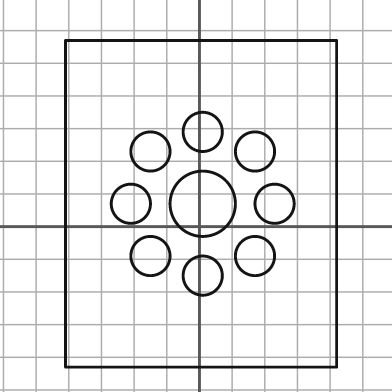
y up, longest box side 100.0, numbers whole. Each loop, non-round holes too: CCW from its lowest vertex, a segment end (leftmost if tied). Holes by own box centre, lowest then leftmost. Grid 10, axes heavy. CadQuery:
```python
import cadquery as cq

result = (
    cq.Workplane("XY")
    .moveTo(-41.0, -43.0)
    .lineTo(42.0, -43.0)
    .lineTo(42.0, 57.0)
    .lineTo(-41.0, 57.0)
    .close()
    .moveTo(1.0, -15.0)
    .circle(6.0)
    .moveTo(-15.0, -9.0)
    .circle(6.0)
    .moveTo(17.0, -9.0)
    .circle(6.0)
    .moveTo(-21.0, 7.0)
    .circle(6.0)
    .moveTo(1.0, 7.0)
    .circle(10.0)
    .moveTo(23.0, 7.0)
    .circle(6.0)
    .moveTo(-15.0, 23.0)
    .circle(6.0)
    .moveTo(17.0, 23.0)
    .circle(6.0)
    .moveTo(1.0, 29.0)
    .circle(6.0)
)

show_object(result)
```